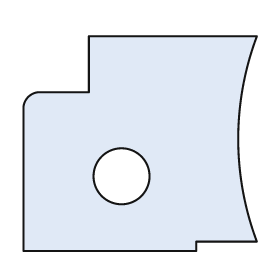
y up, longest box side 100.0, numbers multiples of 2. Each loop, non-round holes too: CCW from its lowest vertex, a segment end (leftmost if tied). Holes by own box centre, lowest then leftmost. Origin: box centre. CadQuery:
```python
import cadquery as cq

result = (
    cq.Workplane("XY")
    .moveTo(-50.0, -46.0)
    .lineTo(24.0, -46.0)
    .lineTo(24.0, -42.0)
    .lineTo(50.0, -42.0)
    .threePointArc((42.0, 2.0), (50.0, 46.0))
    .lineTo(-22.0, 46.0)
    .lineTo(-22.0, 22.0)
    .lineTo(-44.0, 22.0)
    .threePointArc((-48.0, 20.0), (-50.0, 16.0))
    .close()
    .moveTo(-8.0, -14.0)
    .circle(12.0)
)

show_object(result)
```